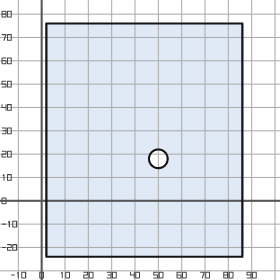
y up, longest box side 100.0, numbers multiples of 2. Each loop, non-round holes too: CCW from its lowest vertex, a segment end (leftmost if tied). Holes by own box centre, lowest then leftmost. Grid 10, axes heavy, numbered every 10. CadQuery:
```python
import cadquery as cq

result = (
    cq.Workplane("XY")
    .moveTo(2.0, -24.0)
    .lineTo(86.0, -24.0)
    .lineTo(86.0, 76.0)
    .lineTo(2.0, 76.0)
    .close()
    .moveTo(50.0, 18.0)
    .circle(4.0)
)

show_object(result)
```